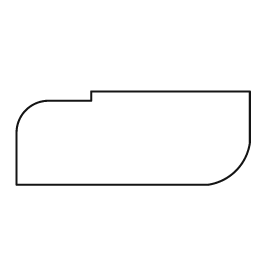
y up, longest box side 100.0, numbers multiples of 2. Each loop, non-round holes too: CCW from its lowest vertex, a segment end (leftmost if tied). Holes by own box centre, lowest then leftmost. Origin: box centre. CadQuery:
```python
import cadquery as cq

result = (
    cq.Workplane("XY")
    .moveTo(-50.0, -20.0)
    .lineTo(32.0, -20.0)
    .threePointArc((44.0, -14.0), (50.0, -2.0))
    .lineTo(50.0, 20.0)
    .lineTo(-18.0, 20.0)
    .lineTo(-18.0, 16.0)
    .lineTo(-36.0, 16.0)
    .threePointArc((-46.0, 12.0), (-50.0, 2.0))
    .close()
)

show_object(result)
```